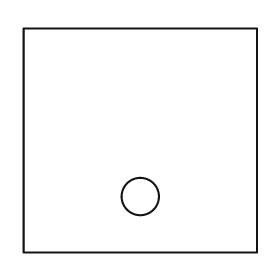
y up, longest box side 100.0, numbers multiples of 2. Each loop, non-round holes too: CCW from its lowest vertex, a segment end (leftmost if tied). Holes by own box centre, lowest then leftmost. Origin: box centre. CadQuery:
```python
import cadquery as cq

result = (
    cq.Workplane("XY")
    .moveTo(-50.0, -48.0)
    .lineTo(50.0, -48.0)
    .lineTo(50.0, 48.0)
    .lineTo(-50.0, 48.0)
    .close()
    .moveTo(0.0, -24.0)
    .circle(8.0)
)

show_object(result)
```